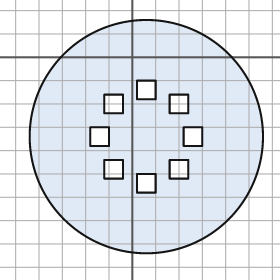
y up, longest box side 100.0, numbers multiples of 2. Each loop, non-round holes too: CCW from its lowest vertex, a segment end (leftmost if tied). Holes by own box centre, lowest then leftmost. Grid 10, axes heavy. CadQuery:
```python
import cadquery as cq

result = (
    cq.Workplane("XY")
    .moveTo(6.0, -34.0)
    .circle(50.0)
    .moveTo(2.0, -58.0)
    .lineTo(10.0, -58.0)
    .lineTo(10.0, -50.0)
    .lineTo(2.0, -50.0)
    .close()
    .moveTo(-12.0, -52.0)
    .lineTo(-4.0, -52.0)
    .lineTo(-4.0, -44.0)
    .lineTo(-12.0, -44.0)
    .close()
    .moveTo(16.0, -52.0)
    .lineTo(24.0, -52.0)
    .lineTo(24.0, -44.0)
    .lineTo(16.0, -44.0)
    .close()
    .moveTo(-18.0, -38.0)
    .lineTo(-10.0, -38.0)
    .lineTo(-10.0, -30.0)
    .lineTo(-18.0, -30.0)
    .close()
    .moveTo(22.0, -38.0)
    .lineTo(30.0, -38.0)
    .lineTo(30.0, -30.0)
    .lineTo(22.0, -30.0)
    .close()
    .moveTo(-12.0, -24.0)
    .lineTo(-4.0, -24.0)
    .lineTo(-4.0, -16.0)
    .lineTo(-12.0, -16.0)
    .close()
    .moveTo(16.0, -24.0)
    .lineTo(24.0, -24.0)
    .lineTo(24.0, -16.0)
    .lineTo(16.0, -16.0)
    .close()
    .moveTo(2.0, -18.0)
    .lineTo(10.0, -18.0)
    .lineTo(10.0, -10.0)
    .lineTo(2.0, -10.0)
    .close()
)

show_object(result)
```